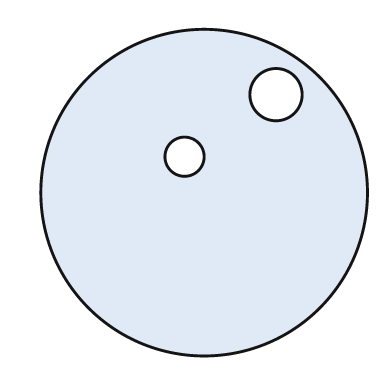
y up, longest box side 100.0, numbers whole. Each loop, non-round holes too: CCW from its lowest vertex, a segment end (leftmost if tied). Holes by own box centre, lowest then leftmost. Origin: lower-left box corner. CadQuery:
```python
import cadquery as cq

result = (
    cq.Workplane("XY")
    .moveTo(50.0, 50.0)
    .circle(50.0)
    .moveTo(44.0, 61.0)
    .circle(6.0)
    .moveTo(72.0, 80.0)
    .circle(8.0)
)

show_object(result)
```